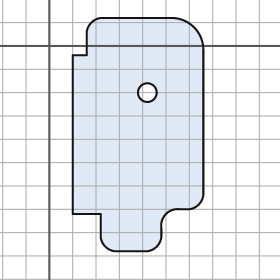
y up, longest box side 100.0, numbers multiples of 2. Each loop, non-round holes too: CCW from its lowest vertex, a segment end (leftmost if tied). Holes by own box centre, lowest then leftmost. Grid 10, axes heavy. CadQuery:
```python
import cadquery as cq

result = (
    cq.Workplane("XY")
    .moveTo(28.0, -88.0)
    .lineTo(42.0, -88.0)
    .threePointArc((46.0, -86.0), (48.0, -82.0))
    .lineTo(48.0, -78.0)
    .threePointArc((50.0, -72.0), (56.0, -70.0))
    .lineTo(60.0, -70.0)
    .threePointArc((64.0, -68.0), (66.0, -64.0))
    .lineTo(66.0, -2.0)
    .threePointArc((62.0, 8.0), (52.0, 12.0))
    .lineTo(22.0, 12.0)
    .threePointArc((18.0, 10.0), (16.0, 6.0))
    .lineTo(16.0, -4.0)
    .lineTo(10.0, -4.0)
    .lineTo(10.0, -72.0)
    .lineTo(22.0, -72.0)
    .lineTo(22.0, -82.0)
    .threePointArc((24.0, -86.0), (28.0, -88.0))
    .close()
    .moveTo(42.0, -20.0)
    .circle(4.0)
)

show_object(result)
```